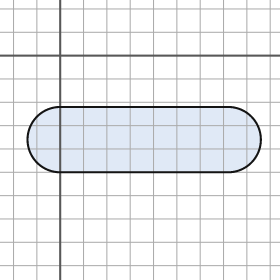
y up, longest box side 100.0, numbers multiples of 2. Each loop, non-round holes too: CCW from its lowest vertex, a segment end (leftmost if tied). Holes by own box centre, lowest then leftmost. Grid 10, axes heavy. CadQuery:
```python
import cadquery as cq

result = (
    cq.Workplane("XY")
    .moveTo(0.0, -50.0)
    .lineTo(72.0, -50.0)
    .threePointArc((86.0, -36.0), (72.0, -22.0))
    .lineTo(0.0, -22.0)
    .threePointArc((-14.0, -36.0), (0.0, -50.0))
    .close()
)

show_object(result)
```